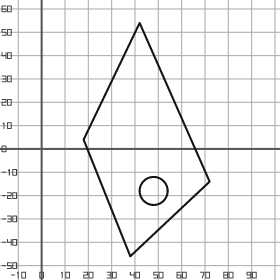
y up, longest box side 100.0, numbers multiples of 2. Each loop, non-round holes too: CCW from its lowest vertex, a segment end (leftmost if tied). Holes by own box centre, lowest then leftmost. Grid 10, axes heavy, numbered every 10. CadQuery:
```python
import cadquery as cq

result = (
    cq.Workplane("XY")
    .moveTo(38.0, -46.0)
    .lineTo(72.0, -14.0)
    .lineTo(42.0, 54.0)
    .lineTo(18.0, 4.0)
    .close()
    .moveTo(48.0, -18.0)
    .circle(6.0)
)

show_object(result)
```